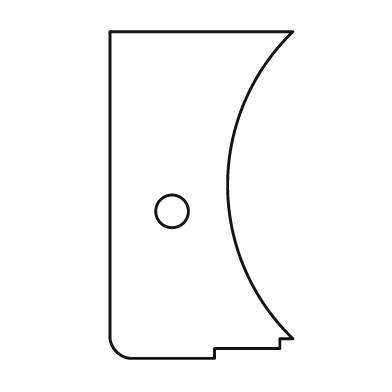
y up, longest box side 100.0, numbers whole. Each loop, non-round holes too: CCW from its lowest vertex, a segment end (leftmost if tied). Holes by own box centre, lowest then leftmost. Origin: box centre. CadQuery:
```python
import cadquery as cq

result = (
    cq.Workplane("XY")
    .moveTo(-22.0, -50.0)
    .lineTo(4.0, -50.0)
    .lineTo(4.0, -47.0)
    .lineTo(24.0, -47.0)
    .lineTo(24.0, -44.0)
    .lineTo(28.0, -44.0)
    .threePointArc((8.0, 3.0), (28.0, 50.0))
    .lineTo(-28.0, 50.0)
    .lineTo(-28.0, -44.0)
    .threePointArc((-26.0, -48.0), (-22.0, -50.0))
    .close()
    .moveTo(-9.0, -5.0)
    .circle(5.0)
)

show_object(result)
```